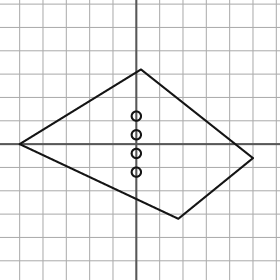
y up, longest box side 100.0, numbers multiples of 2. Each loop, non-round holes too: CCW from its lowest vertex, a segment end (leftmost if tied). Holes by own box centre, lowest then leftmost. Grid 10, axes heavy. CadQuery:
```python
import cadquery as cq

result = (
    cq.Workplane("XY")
    .moveTo(18.0, -32.0)
    .lineTo(50.0, -6.0)
    .lineTo(2.0, 32.0)
    .lineTo(-50.0, 0.0)
    .close()
    .moveTo(0.0, -12.0)
    .circle(2.0)
    .moveTo(0.0, -4.0)
    .circle(2.0)
    .moveTo(0.0, 4.0)
    .circle(2.0)
    .moveTo(0.0, 12.0)
    .circle(2.0)
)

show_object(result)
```